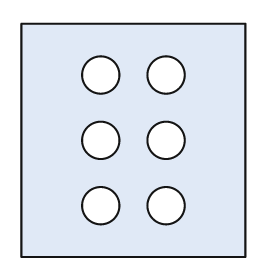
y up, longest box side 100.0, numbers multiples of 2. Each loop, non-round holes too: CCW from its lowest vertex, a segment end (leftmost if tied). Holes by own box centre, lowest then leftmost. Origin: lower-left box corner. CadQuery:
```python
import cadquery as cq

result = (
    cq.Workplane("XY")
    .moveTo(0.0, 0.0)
    .lineTo(96.0, 0.0)
    .lineTo(96.0, 100.0)
    .lineTo(0.0, 100.0)
    .close()
    .moveTo(34.0, 22.0)
    .circle(8.0)
    .moveTo(62.0, 22.0)
    .circle(8.0)
    .moveTo(34.0, 50.0)
    .circle(8.0)
    .moveTo(62.0, 50.0)
    .circle(8.0)
    .moveTo(34.0, 78.0)
    .circle(8.0)
    .moveTo(62.0, 78.0)
    .circle(8.0)
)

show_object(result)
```